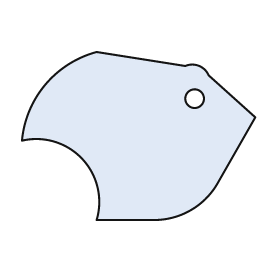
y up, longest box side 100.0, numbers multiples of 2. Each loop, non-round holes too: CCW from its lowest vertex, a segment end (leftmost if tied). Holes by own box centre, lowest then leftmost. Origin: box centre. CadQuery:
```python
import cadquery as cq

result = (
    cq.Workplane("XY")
    .moveTo(-18.0, -36.0)
    .lineTo(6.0, -36.0)
    .threePointArc((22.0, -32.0), (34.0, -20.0))
    .lineTo(50.0, 8.0)
    .lineTo(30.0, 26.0)
    .threePointArc((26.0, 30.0), (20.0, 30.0))
    .lineTo(-18.0, 36.0)
    .threePointArc((-40.0, 22.0), (-50.0, -2.0))
    .threePointArc((-24.0, -10.0), (-18.0, -36.0))
    .close()
    .moveTo(24.0, 16.0)
    .circle(4.0)
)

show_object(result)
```